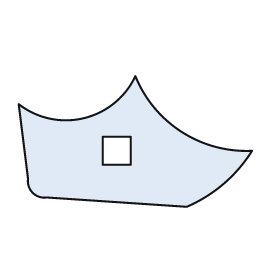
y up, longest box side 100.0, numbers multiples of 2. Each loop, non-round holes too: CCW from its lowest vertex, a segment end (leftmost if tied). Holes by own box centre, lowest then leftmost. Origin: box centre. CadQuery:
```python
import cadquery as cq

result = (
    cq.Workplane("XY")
    .moveTo(22.0, -28.0)
    .threePointArc((38.0, -18.0), (50.0, -4.0))
    .threePointArc((20.0, 4.0), (0.0, 28.0))
    .threePointArc((-22.0, 10.0), (-50.0, 16.0))
    .lineTo(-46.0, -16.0)
    .threePointArc((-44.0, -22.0), (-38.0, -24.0))
    .close()
    .moveTo(-14.0, -10.0)
    .lineTo(-2.0, -10.0)
    .lineTo(-2.0, 2.0)
    .lineTo(-14.0, 2.0)
    .close()
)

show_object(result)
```